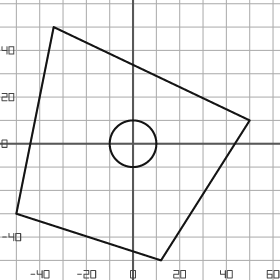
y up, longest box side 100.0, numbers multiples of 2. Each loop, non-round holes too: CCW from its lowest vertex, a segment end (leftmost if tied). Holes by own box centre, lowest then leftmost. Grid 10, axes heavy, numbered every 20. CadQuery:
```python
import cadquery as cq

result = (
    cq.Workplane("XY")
    .moveTo(12.0, -50.0)
    .lineTo(50.0, 10.0)
    .lineTo(-34.0, 50.0)
    .lineTo(-50.0, -30.0)
    .close()
    .moveTo(0.0, 0.0)
    .circle(10.0)
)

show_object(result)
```